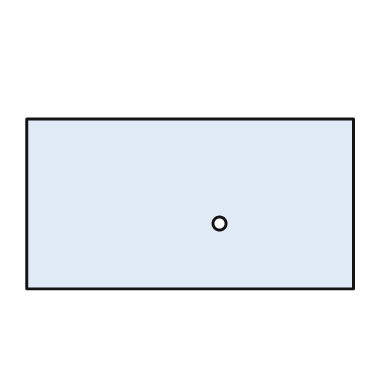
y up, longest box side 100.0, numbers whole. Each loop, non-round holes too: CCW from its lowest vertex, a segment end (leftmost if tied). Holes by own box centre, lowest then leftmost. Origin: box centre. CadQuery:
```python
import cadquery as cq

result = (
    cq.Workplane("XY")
    .moveTo(-50.0, -26.0)
    .lineTo(50.0, -26.0)
    .lineTo(50.0, 26.0)
    .lineTo(-50.0, 26.0)
    .close()
    .moveTo(9.0, -6.0)
    .circle(2.0)
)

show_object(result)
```